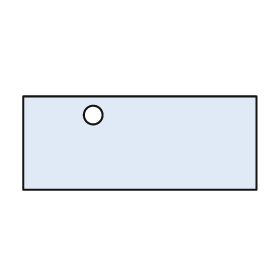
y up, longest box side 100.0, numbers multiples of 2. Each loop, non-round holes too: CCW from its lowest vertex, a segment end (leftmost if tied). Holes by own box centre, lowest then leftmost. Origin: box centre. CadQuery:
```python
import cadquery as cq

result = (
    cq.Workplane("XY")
    .moveTo(-50.0, -20.0)
    .lineTo(50.0, -20.0)
    .lineTo(50.0, 20.0)
    .lineTo(-50.0, 20.0)
    .close()
    .moveTo(-20.0, 12.0)
    .circle(4.0)
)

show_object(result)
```